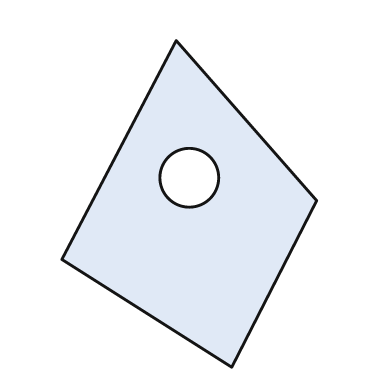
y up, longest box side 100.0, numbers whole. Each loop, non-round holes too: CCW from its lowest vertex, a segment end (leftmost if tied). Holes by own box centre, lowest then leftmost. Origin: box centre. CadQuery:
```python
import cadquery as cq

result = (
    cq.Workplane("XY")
    .moveTo(13.0, -50.0)
    .lineTo(39.0, 1.0)
    .lineTo(-4.0, 50.0)
    .lineTo(-39.0, -17.0)
    .close()
    .moveTo(0.0, 8.0)
    .circle(9.0)
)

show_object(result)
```